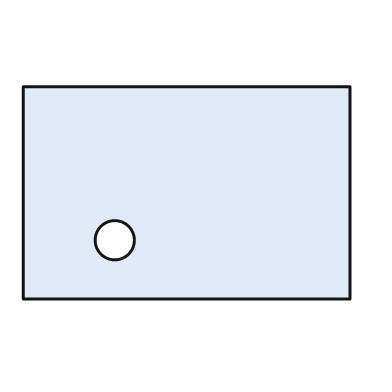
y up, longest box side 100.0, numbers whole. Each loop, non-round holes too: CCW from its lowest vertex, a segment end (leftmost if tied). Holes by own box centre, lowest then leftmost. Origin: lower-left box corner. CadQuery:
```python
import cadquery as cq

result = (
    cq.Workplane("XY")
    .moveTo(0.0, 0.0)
    .lineTo(100.0, 0.0)
    .lineTo(100.0, 65.0)
    .lineTo(0.0, 65.0)
    .close()
    .moveTo(28.0, 18.0)
    .circle(6.0)
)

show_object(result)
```